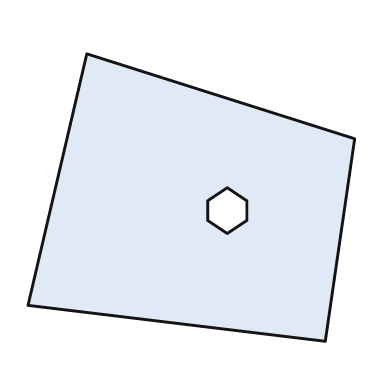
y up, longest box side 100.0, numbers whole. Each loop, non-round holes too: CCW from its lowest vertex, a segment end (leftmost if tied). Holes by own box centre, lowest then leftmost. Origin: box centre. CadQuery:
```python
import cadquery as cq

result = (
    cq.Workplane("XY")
    .moveTo(41.0, -44.0)
    .lineTo(50.0, 18.0)
    .lineTo(-32.0, 44.0)
    .lineTo(-50.0, -33.0)
    .close()
    .moveTo(11.0, -11.0)
    .lineTo(17.0, -7.0)
    .lineTo(17.0, -1.0)
    .lineTo(11.0, 3.0)
    .lineTo(5.0, -1.0)
    .lineTo(5.0, -7.0)
    .close()
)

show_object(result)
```